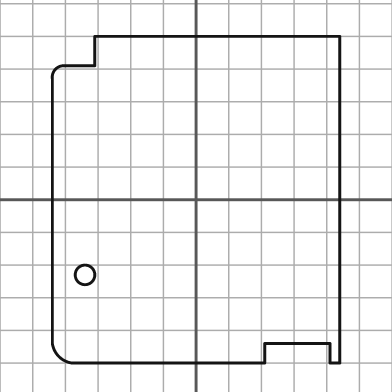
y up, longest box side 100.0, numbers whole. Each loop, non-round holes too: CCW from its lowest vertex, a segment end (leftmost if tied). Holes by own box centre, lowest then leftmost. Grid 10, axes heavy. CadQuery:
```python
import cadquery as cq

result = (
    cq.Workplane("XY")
    .moveTo(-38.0, -50.0)
    .lineTo(21.0, -50.0)
    .lineTo(21.0, -44.0)
    .lineTo(41.0, -44.0)
    .lineTo(41.0, -50.0)
    .lineTo(44.0, -50.0)
    .lineTo(44.0, 50.0)
    .lineTo(-31.0, 50.0)
    .lineTo(-31.0, 41.0)
    .lineTo(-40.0, 41.0)
    .threePointArc((-43.0, 40.0), (-44.0, 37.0))
    .lineTo(-44.0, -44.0)
    .threePointArc((-42.0, -48.0), (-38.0, -50.0))
    .close()
    .moveTo(-34.0, -23.0)
    .circle(3.0)
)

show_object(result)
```